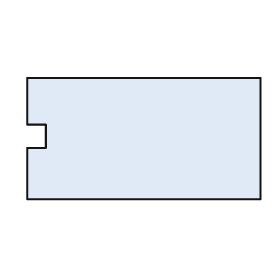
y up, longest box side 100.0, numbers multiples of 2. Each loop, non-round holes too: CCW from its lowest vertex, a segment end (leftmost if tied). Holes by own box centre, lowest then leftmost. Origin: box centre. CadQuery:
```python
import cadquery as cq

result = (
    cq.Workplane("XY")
    .moveTo(-50.0, -26.0)
    .lineTo(50.0, -26.0)
    .lineTo(50.0, 26.0)
    .lineTo(-50.0, 26.0)
    .lineTo(-50.0, 6.0)
    .lineTo(-42.0, 6.0)
    .lineTo(-42.0, -4.0)
    .lineTo(-50.0, -4.0)
    .close()
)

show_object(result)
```